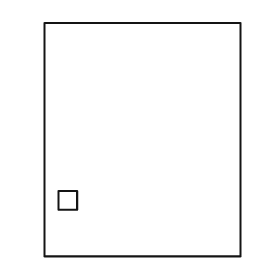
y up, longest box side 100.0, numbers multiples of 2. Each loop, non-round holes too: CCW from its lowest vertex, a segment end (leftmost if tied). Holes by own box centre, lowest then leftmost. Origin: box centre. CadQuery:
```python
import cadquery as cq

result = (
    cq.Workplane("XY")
    .moveTo(-42.0, -50.0)
    .lineTo(42.0, -50.0)
    .lineTo(42.0, 50.0)
    .lineTo(-42.0, 50.0)
    .close()
    .moveTo(-36.0, -30.0)
    .lineTo(-28.0, -30.0)
    .lineTo(-28.0, -22.0)
    .lineTo(-36.0, -22.0)
    .close()
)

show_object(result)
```